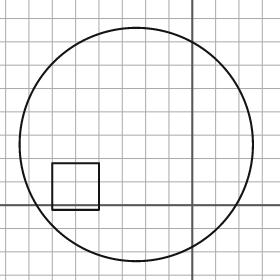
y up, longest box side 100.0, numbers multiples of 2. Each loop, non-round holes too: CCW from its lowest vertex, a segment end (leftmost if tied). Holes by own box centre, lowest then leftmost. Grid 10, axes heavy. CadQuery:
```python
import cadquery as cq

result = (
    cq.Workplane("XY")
    .moveTo(-24.0, 26.0)
    .circle(50.0)
    .moveTo(-60.0, -2.0)
    .lineTo(-40.0, -2.0)
    .lineTo(-40.0, 18.0)
    .lineTo(-60.0, 18.0)
    .close()
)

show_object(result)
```